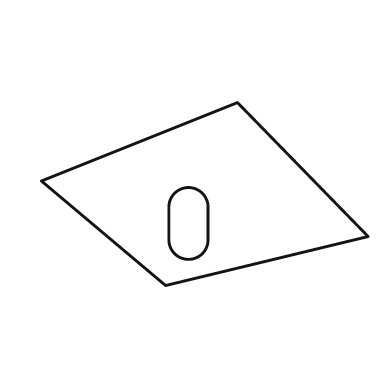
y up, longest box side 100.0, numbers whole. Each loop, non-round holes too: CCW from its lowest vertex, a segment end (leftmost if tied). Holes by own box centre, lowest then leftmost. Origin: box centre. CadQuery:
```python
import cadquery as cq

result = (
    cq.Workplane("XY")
    .moveTo(-12.0, -28.0)
    .lineTo(50.0, -13.0)
    .lineTo(10.0, 28.0)
    .lineTo(-50.0, 4.0)
    .close()
    .moveTo(-11.0, -14.0)
    .threePointArc((-5.0, -20.0), (1.0, -14.0))
    .lineTo(1.0, -4.0)
    .threePointArc((-5.0, 2.0), (-11.0, -4.0))
    .close()
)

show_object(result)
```